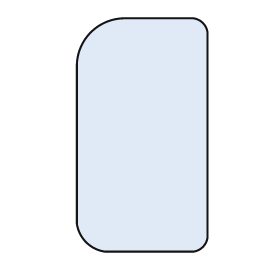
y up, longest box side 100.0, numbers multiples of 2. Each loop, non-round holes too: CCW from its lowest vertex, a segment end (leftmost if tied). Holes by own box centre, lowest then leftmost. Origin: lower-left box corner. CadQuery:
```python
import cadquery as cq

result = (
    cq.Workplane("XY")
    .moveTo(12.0, 0.0)
    .lineTo(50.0, 0.0)
    .threePointArc((54.0, 2.0), (56.0, 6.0))
    .lineTo(56.0, 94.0)
    .threePointArc((54.0, 98.0), (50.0, 100.0))
    .lineTo(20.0, 100.0)
    .threePointArc((6.0, 94.0), (0.0, 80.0))
    .lineTo(0.0, 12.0)
    .threePointArc((4.0, 4.0), (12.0, 0.0))
    .close()
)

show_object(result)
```